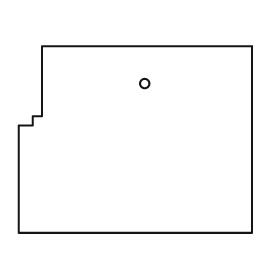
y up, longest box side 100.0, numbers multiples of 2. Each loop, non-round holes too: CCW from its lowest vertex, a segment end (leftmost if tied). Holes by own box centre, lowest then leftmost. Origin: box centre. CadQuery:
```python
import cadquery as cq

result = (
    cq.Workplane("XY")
    .moveTo(-50.0, -40.0)
    .lineTo(50.0, -40.0)
    .lineTo(50.0, 40.0)
    .lineTo(-40.0, 40.0)
    .lineTo(-40.0, 10.0)
    .lineTo(-44.0, 10.0)
    .lineTo(-44.0, 6.0)
    .lineTo(-50.0, 6.0)
    .close()
    .moveTo(4.0, 24.0)
    .circle(2.0)
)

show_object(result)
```